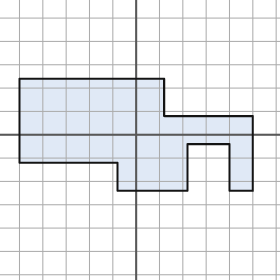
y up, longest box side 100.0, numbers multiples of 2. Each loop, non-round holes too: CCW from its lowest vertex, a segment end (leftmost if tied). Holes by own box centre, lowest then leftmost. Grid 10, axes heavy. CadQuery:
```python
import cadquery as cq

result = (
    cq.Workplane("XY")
    .moveTo(-8.0, -24.0)
    .lineTo(22.0, -24.0)
    .lineTo(22.0, -4.0)
    .lineTo(40.0, -4.0)
    .lineTo(40.0, -24.0)
    .lineTo(50.0, -24.0)
    .lineTo(50.0, 8.0)
    .lineTo(12.0, 8.0)
    .lineTo(12.0, 24.0)
    .lineTo(-50.0, 24.0)
    .lineTo(-50.0, -12.0)
    .lineTo(-8.0, -12.0)
    .close()
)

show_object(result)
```